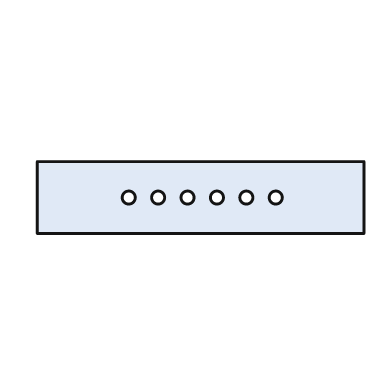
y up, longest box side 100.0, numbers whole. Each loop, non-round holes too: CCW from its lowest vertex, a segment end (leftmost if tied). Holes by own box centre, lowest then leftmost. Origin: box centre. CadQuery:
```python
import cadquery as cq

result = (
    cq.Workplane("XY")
    .moveTo(-50.0, -11.0)
    .lineTo(50.0, -11.0)
    .lineTo(50.0, 11.0)
    .lineTo(-50.0, 11.0)
    .close()
    .moveTo(-22.0, 0.0)
    .circle(2.0)
    .moveTo(-13.0, 0.0)
    .circle(2.0)
    .moveTo(-4.0, 0.0)
    .circle(2.0)
    .moveTo(5.0, 0.0)
    .circle(2.0)
    .moveTo(14.0, 0.0)
    .circle(2.0)
    .moveTo(23.0, 0.0)
    .circle(2.0)
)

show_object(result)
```